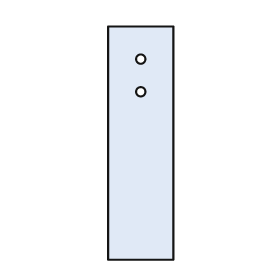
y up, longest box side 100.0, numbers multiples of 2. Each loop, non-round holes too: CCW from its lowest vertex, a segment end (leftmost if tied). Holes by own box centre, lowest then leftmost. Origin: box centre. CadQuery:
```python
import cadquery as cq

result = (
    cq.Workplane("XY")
    .moveTo(-14.0, -50.0)
    .lineTo(14.0, -50.0)
    .lineTo(14.0, 50.0)
    .lineTo(-14.0, 50.0)
    .close()
    .moveTo(0.0, 22.0)
    .circle(2.0)
    .moveTo(0.0, 36.0)
    .circle(2.0)
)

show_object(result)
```